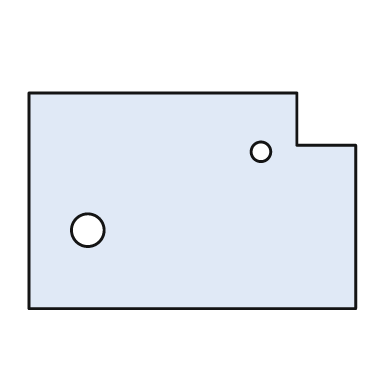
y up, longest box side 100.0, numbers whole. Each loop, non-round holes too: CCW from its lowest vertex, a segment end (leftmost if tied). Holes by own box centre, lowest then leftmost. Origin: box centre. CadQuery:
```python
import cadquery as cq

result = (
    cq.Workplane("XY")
    .moveTo(-50.0, -33.0)
    .lineTo(50.0, -33.0)
    .lineTo(50.0, 17.0)
    .lineTo(32.0, 17.0)
    .lineTo(32.0, 33.0)
    .lineTo(-50.0, 33.0)
    .close()
    .moveTo(-32.0, -9.0)
    .circle(5.0)
    .moveTo(21.0, 15.0)
    .circle(3.0)
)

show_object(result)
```